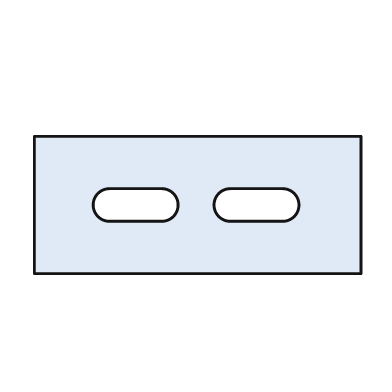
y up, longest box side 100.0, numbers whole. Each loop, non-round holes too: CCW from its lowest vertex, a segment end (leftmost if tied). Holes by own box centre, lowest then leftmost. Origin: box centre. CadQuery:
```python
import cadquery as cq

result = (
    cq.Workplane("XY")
    .moveTo(-50.0, -21.0)
    .lineTo(50.0, -21.0)
    .lineTo(50.0, 21.0)
    .lineTo(-50.0, 21.0)
    .close()
    .moveTo(-27.0, -5.0)
    .lineTo(-11.0, -5.0)
    .threePointArc((-6.0, 0.0), (-11.0, 5.0))
    .lineTo(-27.0, 5.0)
    .threePointArc((-32.0, 0.0), (-27.0, -5.0))
    .close()
    .moveTo(10.0, -5.0)
    .lineTo(26.0, -5.0)
    .threePointArc((31.0, 0.0), (26.0, 5.0))
    .lineTo(10.0, 5.0)
    .threePointArc((5.0, 0.0), (10.0, -5.0))
    .close()
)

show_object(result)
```